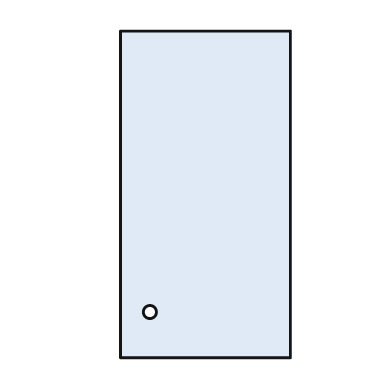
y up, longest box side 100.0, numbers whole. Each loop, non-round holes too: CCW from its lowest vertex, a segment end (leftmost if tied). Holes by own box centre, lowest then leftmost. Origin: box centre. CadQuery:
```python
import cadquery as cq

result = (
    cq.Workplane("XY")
    .moveTo(-26.0, -50.0)
    .lineTo(26.0, -50.0)
    .lineTo(26.0, 50.0)
    .lineTo(-26.0, 50.0)
    .close()
    .moveTo(-17.0, -36.0)
    .circle(2.0)
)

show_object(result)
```